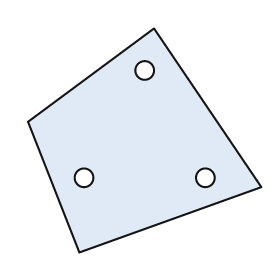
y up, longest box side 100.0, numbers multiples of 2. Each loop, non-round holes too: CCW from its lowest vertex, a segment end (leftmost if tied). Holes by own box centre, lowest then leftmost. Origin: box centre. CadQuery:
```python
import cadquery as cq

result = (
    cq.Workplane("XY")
    .moveTo(-28.0, -48.0)
    .lineTo(50.0, -20.0)
    .lineTo(4.0, 48.0)
    .lineTo(-50.0, 8.0)
    .close()
    .moveTo(-26.0, -16.0)
    .circle(4.0)
    .moveTo(26.0, -16.0)
    .circle(4.0)
    .moveTo(0.0, 30.0)
    .circle(4.0)
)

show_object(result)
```